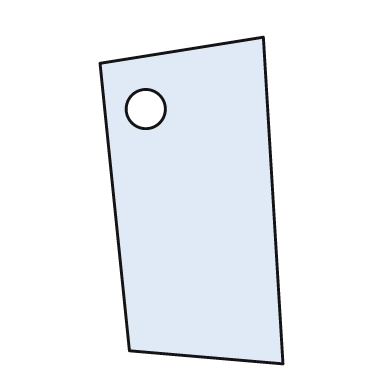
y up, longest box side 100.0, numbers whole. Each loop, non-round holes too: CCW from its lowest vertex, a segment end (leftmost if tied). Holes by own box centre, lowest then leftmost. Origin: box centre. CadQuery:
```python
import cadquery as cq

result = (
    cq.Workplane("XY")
    .moveTo(28.0, -50.0)
    .lineTo(22.0, 50.0)
    .lineTo(-28.0, 42.0)
    .lineTo(-19.0, -46.0)
    .close()
    .moveTo(-14.0, 28.0)
    .circle(6.0)
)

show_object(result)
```